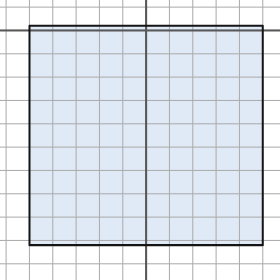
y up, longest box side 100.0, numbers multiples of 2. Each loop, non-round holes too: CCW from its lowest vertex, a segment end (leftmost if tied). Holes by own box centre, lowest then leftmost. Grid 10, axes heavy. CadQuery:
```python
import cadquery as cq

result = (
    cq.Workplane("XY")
    .moveTo(-50.0, -92.0)
    .lineTo(50.0, -92.0)
    .lineTo(50.0, 2.0)
    .lineTo(-50.0, 2.0)
    .close()
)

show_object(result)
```